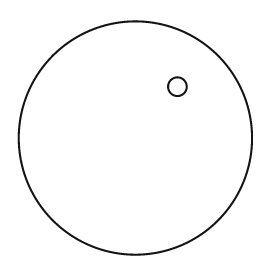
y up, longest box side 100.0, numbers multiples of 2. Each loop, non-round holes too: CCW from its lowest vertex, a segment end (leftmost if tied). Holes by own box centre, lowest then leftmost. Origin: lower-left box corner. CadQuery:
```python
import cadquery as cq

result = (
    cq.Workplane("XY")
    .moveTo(50.0, 50.0)
    .circle(50.0)
    .moveTo(68.0, 72.0)
    .circle(4.0)
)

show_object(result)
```